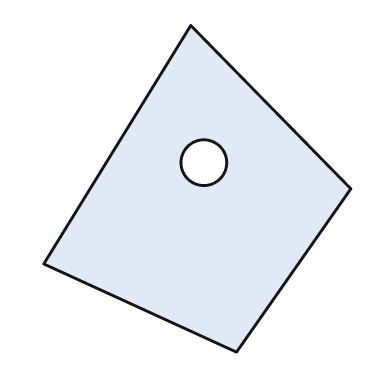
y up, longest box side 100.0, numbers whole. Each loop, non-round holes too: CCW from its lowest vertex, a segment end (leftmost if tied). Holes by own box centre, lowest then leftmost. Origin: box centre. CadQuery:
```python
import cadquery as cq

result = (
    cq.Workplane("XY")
    .moveTo(12.0, -50.0)
    .lineTo(47.0, 0.0)
    .lineTo(-2.0, 50.0)
    .lineTo(-47.0, -23.0)
    .close()
    .moveTo(2.0, 8.0)
    .circle(7.0)
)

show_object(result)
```